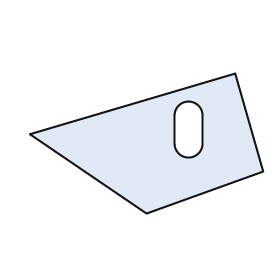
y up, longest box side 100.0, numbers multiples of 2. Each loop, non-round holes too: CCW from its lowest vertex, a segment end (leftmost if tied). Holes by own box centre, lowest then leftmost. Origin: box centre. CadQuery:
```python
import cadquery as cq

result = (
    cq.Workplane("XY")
    .moveTo(0.0, -30.0)
    .lineTo(50.0, -12.0)
    .lineTo(38.0, 30.0)
    .lineTo(-50.0, 4.0)
    .close()
    .moveTo(12.0, 0.0)
    .threePointArc((18.0, -6.0), (24.0, 0.0))
    .lineTo(24.0, 12.0)
    .threePointArc((18.0, 18.0), (12.0, 12.0))
    .close()
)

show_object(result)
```